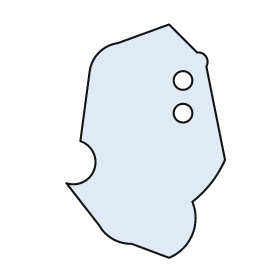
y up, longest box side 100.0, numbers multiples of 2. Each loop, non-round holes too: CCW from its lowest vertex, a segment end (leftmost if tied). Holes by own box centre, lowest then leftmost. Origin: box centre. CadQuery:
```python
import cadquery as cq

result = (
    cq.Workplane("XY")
    .moveTo(10.0, -50.0)
    .threePointArc((20.0, -40.0), (20.0, -26.0))
    .threePointArc((28.0, -18.0), (34.0, -8.0))
    .lineTo(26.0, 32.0)
    .threePointArc((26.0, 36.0), (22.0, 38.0))
    .lineTo(10.0, 50.0)
    .lineTo(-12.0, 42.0)
    .threePointArc((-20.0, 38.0), (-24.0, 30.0))
    .lineTo(-28.0, 0.0)
    .threePointArc((-22.0, -12.0), (-34.0, -18.0))
    .lineTo(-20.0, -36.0)
    .threePointArc((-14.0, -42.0), (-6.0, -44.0))
    .close()
    .moveTo(16.0, 12.0)
    .circle(4.0)
    .moveTo(16.0, 26.0)
    .circle(4.0)
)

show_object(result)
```